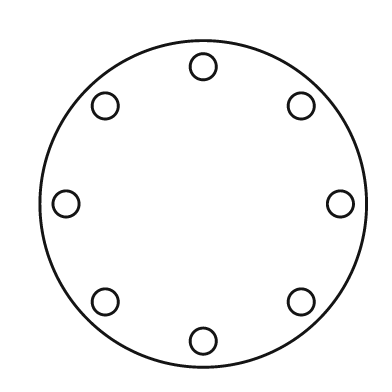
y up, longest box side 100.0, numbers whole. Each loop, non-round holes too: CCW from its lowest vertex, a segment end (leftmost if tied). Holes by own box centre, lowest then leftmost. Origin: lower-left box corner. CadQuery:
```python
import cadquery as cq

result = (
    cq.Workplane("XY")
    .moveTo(50.0, 50.0)
    .circle(50.0)
    .moveTo(50.0, 8.0)
    .circle(4.0)
    .moveTo(20.0, 20.0)
    .circle(4.0)
    .moveTo(80.0, 20.0)
    .circle(4.0)
    .moveTo(8.0, 50.0)
    .circle(4.0)
    .moveTo(92.0, 50.0)
    .circle(4.0)
    .moveTo(20.0, 80.0)
    .circle(4.0)
    .moveTo(80.0, 80.0)
    .circle(4.0)
    .moveTo(50.0, 92.0)
    .circle(4.0)
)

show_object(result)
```